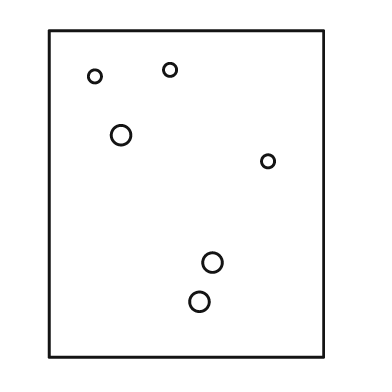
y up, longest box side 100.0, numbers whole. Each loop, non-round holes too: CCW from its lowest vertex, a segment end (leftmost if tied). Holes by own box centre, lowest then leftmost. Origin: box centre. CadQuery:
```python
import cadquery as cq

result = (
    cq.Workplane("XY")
    .moveTo(-42.0, -50.0)
    .lineTo(42.0, -50.0)
    .lineTo(42.0, 50.0)
    .lineTo(-42.0, 50.0)
    .close()
    .moveTo(4.0, -33.0)
    .circle(3.0)
    .moveTo(8.0, -21.0)
    .circle(3.0)
    .moveTo(25.0, 10.0)
    .circle(2.0)
    .moveTo(-20.0, 18.0)
    .circle(3.0)
    .moveTo(-28.0, 36.0)
    .circle(2.0)
    .moveTo(-5.0, 38.0)
    .circle(2.0)
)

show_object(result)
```